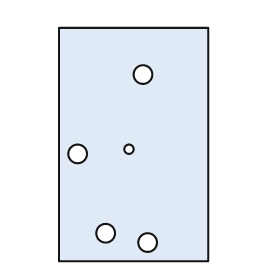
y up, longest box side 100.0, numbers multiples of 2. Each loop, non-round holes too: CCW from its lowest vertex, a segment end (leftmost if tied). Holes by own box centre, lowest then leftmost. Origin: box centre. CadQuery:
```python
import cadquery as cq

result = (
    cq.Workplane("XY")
    .moveTo(-32.0, -50.0)
    .lineTo(32.0, -50.0)
    .lineTo(32.0, 50.0)
    .lineTo(-32.0, 50.0)
    .close()
    .moveTo(6.0, -42.0)
    .circle(4.0)
    .moveTo(-12.0, -38.0)
    .circle(4.0)
    .moveTo(-24.0, -4.0)
    .circle(4.0)
    .moveTo(-2.0, -2.0)
    .circle(2.0)
    .moveTo(4.0, 30.0)
    .circle(4.0)
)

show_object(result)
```